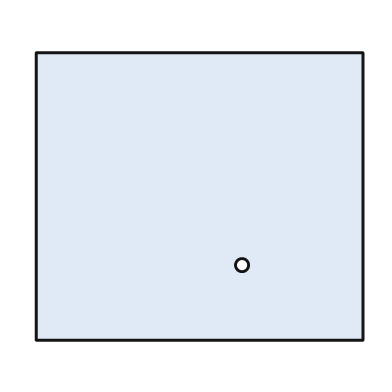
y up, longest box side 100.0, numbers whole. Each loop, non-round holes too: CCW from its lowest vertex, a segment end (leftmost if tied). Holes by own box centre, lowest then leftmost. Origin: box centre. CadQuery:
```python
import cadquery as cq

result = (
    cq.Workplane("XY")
    .moveTo(-50.0, -44.0)
    .lineTo(50.0, -44.0)
    .lineTo(50.0, 44.0)
    .lineTo(-50.0, 44.0)
    .close()
    .moveTo(13.0, -21.0)
    .circle(2.0)
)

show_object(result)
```